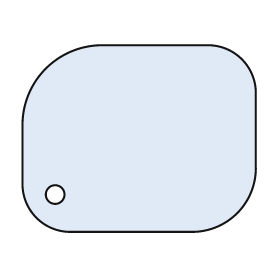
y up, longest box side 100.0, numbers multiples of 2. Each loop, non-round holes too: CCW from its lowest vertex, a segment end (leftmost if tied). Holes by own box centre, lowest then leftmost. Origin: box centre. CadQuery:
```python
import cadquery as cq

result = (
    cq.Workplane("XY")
    .moveTo(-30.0, -40.0)
    .lineTo(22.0, -40.0)
    .threePointArc((42.0, -32.0), (50.0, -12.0))
    .lineTo(50.0, 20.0)
    .threePointArc((44.0, 34.0), (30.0, 40.0))
    .lineTo(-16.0, 40.0)
    .threePointArc((-40.0, 30.0), (-50.0, 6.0))
    .lineTo(-50.0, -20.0)
    .threePointArc((-44.0, -34.0), (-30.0, -40.0))
    .close()
    .moveTo(-36.0, -24.0)
    .circle(4.0)
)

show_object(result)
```